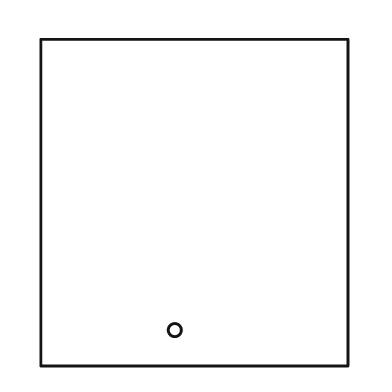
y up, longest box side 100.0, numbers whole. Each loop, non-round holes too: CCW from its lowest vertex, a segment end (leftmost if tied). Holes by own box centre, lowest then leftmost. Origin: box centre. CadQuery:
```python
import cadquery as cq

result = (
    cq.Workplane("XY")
    .moveTo(-47.0, -50.0)
    .lineTo(47.0, -50.0)
    .lineTo(47.0, 50.0)
    .lineTo(-47.0, 50.0)
    .close()
    .moveTo(-6.0, -39.0)
    .circle(2.0)
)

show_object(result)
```